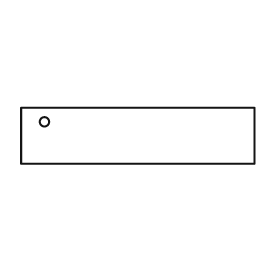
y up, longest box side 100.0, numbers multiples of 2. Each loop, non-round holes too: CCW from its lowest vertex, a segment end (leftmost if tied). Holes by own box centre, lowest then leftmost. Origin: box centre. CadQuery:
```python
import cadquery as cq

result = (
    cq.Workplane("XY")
    .moveTo(-50.0, -12.0)
    .lineTo(50.0, -12.0)
    .lineTo(50.0, 12.0)
    .lineTo(-50.0, 12.0)
    .close()
    .moveTo(-40.0, 6.0)
    .circle(2.0)
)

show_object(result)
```